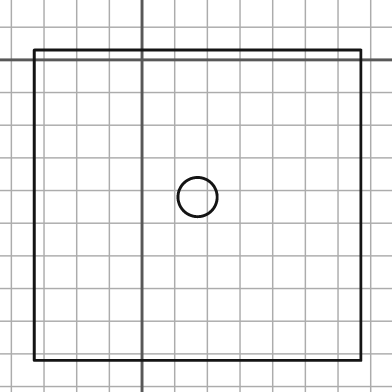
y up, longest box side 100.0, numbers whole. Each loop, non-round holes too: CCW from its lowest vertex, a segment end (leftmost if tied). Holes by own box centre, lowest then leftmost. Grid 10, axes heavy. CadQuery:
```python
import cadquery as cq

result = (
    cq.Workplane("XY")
    .moveTo(-33.0, -92.0)
    .lineTo(67.0, -92.0)
    .lineTo(67.0, 3.0)
    .lineTo(-33.0, 3.0)
    .close()
    .moveTo(17.0, -42.0)
    .circle(6.0)
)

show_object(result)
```